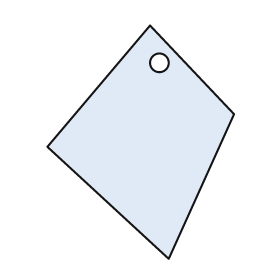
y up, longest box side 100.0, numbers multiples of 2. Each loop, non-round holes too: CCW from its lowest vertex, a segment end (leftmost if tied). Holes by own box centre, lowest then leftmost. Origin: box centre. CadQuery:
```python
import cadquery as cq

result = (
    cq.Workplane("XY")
    .moveTo(12.0, -50.0)
    .lineTo(40.0, 12.0)
    .lineTo(4.0, 50.0)
    .lineTo(-40.0, -2.0)
    .close()
    .moveTo(8.0, 34.0)
    .circle(4.0)
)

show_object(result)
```